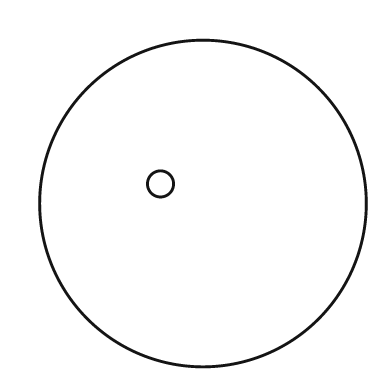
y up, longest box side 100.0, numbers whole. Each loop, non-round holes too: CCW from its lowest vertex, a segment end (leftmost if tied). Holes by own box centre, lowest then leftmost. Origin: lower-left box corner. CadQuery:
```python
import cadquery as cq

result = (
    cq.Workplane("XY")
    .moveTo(50.0, 50.0)
    .circle(50.0)
    .moveTo(37.0, 56.0)
    .circle(4.0)
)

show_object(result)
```